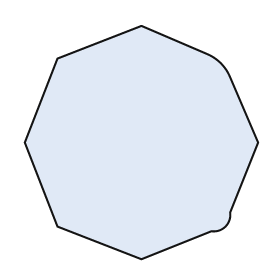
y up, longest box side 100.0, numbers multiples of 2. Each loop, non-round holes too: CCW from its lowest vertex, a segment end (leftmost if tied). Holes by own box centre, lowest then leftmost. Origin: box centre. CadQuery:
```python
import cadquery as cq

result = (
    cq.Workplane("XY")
    .moveTo(0.0, -50.0)
    .lineTo(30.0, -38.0)
    .threePointArc((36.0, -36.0), (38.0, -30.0))
    .lineTo(50.0, 0.0)
    .lineTo(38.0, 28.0)
    .threePointArc((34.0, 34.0), (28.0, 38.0))
    .lineTo(0.0, 50.0)
    .lineTo(-36.0, 36.0)
    .lineTo(-50.0, 0.0)
    .lineTo(-36.0, -36.0)
    .close()
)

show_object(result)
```